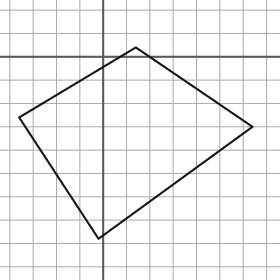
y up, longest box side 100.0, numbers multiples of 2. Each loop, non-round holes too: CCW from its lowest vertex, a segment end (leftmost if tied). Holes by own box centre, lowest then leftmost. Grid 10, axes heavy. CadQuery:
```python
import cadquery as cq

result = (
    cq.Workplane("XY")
    .moveTo(-2.0, -78.0)
    .lineTo(64.0, -30.0)
    .lineTo(14.0, 4.0)
    .lineTo(-36.0, -26.0)
    .close()
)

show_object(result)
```